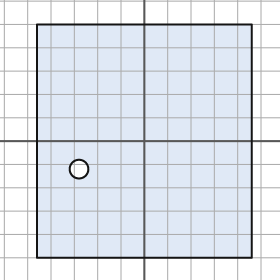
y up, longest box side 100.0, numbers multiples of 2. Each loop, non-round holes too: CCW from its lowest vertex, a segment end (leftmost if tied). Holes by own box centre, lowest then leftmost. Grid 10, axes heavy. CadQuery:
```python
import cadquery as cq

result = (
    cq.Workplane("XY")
    .moveTo(-46.0, -50.0)
    .lineTo(46.0, -50.0)
    .lineTo(46.0, 50.0)
    .lineTo(-46.0, 50.0)
    .close()
    .moveTo(-28.0, -12.0)
    .circle(4.0)
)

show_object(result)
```